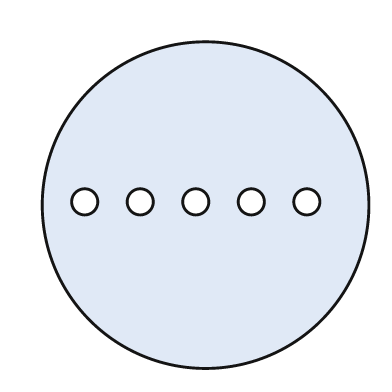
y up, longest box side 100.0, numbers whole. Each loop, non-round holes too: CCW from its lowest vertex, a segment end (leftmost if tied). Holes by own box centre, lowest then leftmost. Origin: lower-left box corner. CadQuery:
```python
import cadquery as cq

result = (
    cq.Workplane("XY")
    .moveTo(50.0, 50.0)
    .circle(50.0)
    .moveTo(13.0, 51.0)
    .circle(4.0)
    .moveTo(30.0, 51.0)
    .circle(4.0)
    .moveTo(47.0, 51.0)
    .circle(4.0)
    .moveTo(64.0, 51.0)
    .circle(4.0)
    .moveTo(81.0, 51.0)
    .circle(4.0)
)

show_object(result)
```